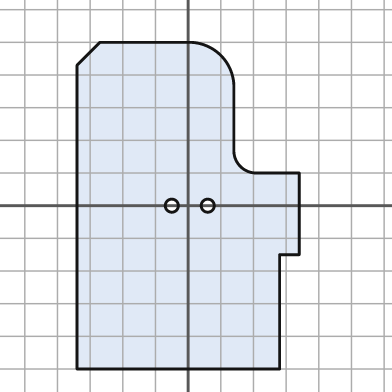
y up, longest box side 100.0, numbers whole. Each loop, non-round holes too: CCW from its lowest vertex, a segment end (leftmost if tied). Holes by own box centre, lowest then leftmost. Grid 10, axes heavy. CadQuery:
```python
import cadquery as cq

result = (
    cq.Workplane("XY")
    .moveTo(-34.0, -50.0)
    .lineTo(28.0, -50.0)
    .lineTo(28.0, -15.0)
    .lineTo(34.0, -15.0)
    .lineTo(34.0, 10.0)
    .lineTo(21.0, 10.0)
    .threePointArc((16.0, 12.0), (14.0, 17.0))
    .lineTo(14.0, 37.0)
    .threePointArc((10.0, 46.0), (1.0, 50.0))
    .lineTo(-27.0, 50.0)
    .lineTo(-34.0, 43.0)
    .close()
    .moveTo(-5.0, 0.0)
    .circle(2.0)
    .moveTo(6.0, 0.0)
    .circle(2.0)
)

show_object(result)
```